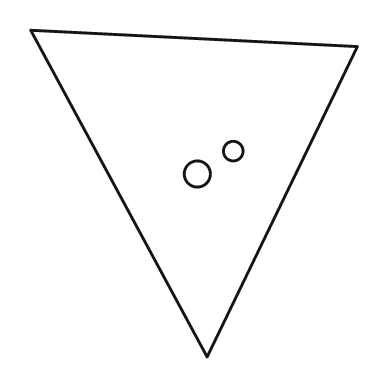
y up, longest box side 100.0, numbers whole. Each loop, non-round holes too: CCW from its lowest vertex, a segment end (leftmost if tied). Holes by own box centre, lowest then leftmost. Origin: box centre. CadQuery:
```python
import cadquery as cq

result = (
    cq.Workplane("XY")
    .moveTo(4.0, -50.0)
    .lineTo(50.0, 45.0)
    .lineTo(-50.0, 50.0)
    .close()
    .moveTo(1.0, 6.0)
    .circle(4.0)
    .moveTo(12.0, 13.0)
    .circle(3.0)
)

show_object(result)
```